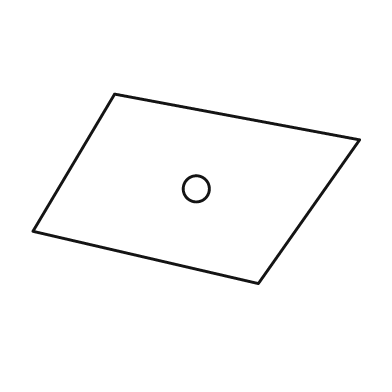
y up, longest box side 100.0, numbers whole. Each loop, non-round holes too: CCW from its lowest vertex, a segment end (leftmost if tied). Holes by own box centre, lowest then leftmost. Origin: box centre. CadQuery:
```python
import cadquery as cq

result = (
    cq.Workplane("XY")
    .moveTo(19.0, -29.0)
    .lineTo(50.0, 15.0)
    .lineTo(-25.0, 29.0)
    .lineTo(-50.0, -13.0)
    .close()
    .moveTo(0.0, 0.0)
    .circle(4.0)
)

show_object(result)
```